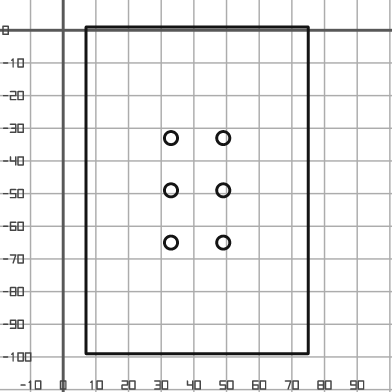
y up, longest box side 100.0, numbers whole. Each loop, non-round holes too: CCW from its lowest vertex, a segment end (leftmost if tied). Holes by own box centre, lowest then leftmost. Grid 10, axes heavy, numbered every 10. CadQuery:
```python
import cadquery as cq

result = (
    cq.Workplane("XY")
    .moveTo(7.0, -99.0)
    .lineTo(75.0, -99.0)
    .lineTo(75.0, 1.0)
    .lineTo(7.0, 1.0)
    .close()
    .moveTo(33.0, -65.0)
    .circle(2.0)
    .moveTo(49.0, -65.0)
    .circle(2.0)
    .moveTo(33.0, -49.0)
    .circle(2.0)
    .moveTo(49.0, -49.0)
    .circle(2.0)
    .moveTo(33.0, -33.0)
    .circle(2.0)
    .moveTo(49.0, -33.0)
    .circle(2.0)
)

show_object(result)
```